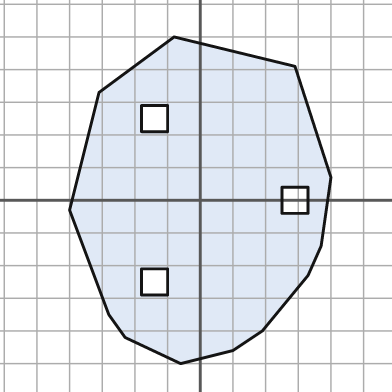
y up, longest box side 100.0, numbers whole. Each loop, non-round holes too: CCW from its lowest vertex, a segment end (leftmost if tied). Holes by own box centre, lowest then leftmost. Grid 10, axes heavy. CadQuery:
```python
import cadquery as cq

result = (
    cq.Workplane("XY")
    .moveTo(-6.0, -50.0)
    .lineTo(10.0, -46.0)
    .lineTo(19.0, -40.0)
    .lineTo(33.0, -23.0)
    .lineTo(37.0, -14.0)
    .lineTo(40.0, 7.0)
    .lineTo(29.0, 41.0)
    .lineTo(-8.0, 50.0)
    .lineTo(-31.0, 33.0)
    .lineTo(-40.0, -3.0)
    .lineTo(-28.0, -35.0)
    .lineTo(-23.0, -42.0)
    .close()
    .moveTo(-18.0, -29.0)
    .lineTo(-10.0, -29.0)
    .lineTo(-10.0, -21.0)
    .lineTo(-18.0, -21.0)
    .close()
    .moveTo(25.0, -4.0)
    .lineTo(33.0, -4.0)
    .lineTo(33.0, 4.0)
    .lineTo(25.0, 4.0)
    .close()
    .moveTo(-18.0, 21.0)
    .lineTo(-10.0, 21.0)
    .lineTo(-10.0, 29.0)
    .lineTo(-18.0, 29.0)
    .close()
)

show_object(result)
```